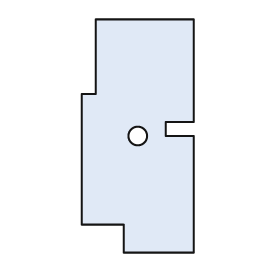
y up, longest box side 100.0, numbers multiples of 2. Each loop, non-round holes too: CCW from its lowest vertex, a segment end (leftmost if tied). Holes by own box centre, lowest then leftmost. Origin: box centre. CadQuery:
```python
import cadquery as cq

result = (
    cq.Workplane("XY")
    .moveTo(-6.0, -50.0)
    .lineTo(24.0, -50.0)
    .lineTo(24.0, 0.0)
    .lineTo(12.0, 0.0)
    .lineTo(12.0, 6.0)
    .lineTo(24.0, 6.0)
    .lineTo(24.0, 50.0)
    .lineTo(-18.0, 50.0)
    .lineTo(-18.0, 18.0)
    .lineTo(-24.0, 18.0)
    .lineTo(-24.0, -38.0)
    .lineTo(-6.0, -38.0)
    .close()
    .moveTo(0.0, 0.0)
    .circle(4.0)
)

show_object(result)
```